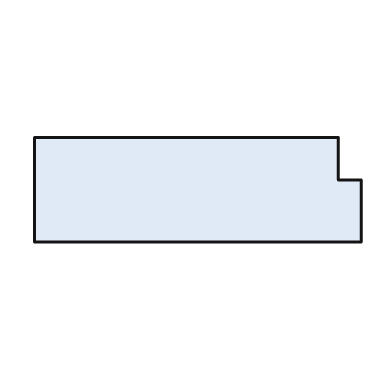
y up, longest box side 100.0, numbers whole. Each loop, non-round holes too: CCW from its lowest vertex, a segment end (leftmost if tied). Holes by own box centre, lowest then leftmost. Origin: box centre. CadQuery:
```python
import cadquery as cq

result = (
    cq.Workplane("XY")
    .moveTo(-50.0, -16.0)
    .lineTo(50.0, -16.0)
    .lineTo(50.0, 3.0)
    .lineTo(43.0, 3.0)
    .lineTo(43.0, 16.0)
    .lineTo(-50.0, 16.0)
    .close()
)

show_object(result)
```